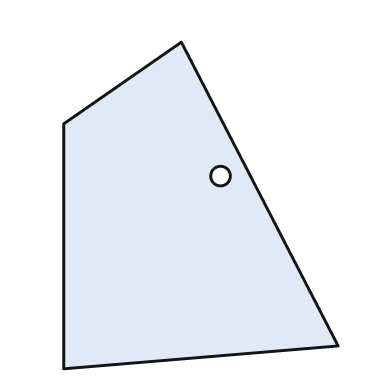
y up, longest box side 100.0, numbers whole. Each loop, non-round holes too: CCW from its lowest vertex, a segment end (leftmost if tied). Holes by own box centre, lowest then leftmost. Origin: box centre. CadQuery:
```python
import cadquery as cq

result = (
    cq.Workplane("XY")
    .moveTo(-42.0, -50.0)
    .lineTo(42.0, -43.0)
    .lineTo(-6.0, 50.0)
    .lineTo(-42.0, 25.0)
    .close()
    .moveTo(6.0, 9.0)
    .circle(3.0)
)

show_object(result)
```